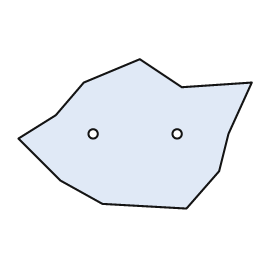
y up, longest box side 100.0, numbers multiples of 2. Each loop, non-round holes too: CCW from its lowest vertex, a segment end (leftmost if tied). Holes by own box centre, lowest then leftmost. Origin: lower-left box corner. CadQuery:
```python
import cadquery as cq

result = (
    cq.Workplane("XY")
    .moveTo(72.0, 0.0)
    .lineTo(86.0, 16.0)
    .lineTo(90.0, 32.0)
    .lineTo(100.0, 54.0)
    .lineTo(70.0, 52.0)
    .lineTo(52.0, 64.0)
    .lineTo(28.0, 54.0)
    .lineTo(16.0, 40.0)
    .lineTo(0.0, 30.0)
    .lineTo(18.0, 12.0)
    .lineTo(36.0, 2.0)
    .close()
    .moveTo(32.0, 32.0)
    .circle(2.0)
    .moveTo(68.0, 32.0)
    .circle(2.0)
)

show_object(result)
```